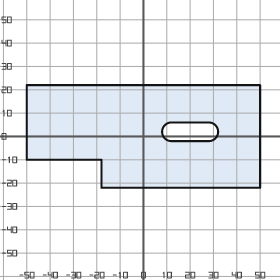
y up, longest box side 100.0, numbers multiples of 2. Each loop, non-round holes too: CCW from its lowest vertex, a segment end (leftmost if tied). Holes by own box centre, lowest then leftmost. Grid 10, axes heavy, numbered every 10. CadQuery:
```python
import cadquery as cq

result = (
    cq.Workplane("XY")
    .moveTo(-18.0, -22.0)
    .lineTo(50.0, -22.0)
    .lineTo(50.0, 22.0)
    .lineTo(-50.0, 22.0)
    .lineTo(-50.0, -10.0)
    .lineTo(-18.0, -10.0)
    .close()
    .moveTo(12.0, -2.0)
    .lineTo(28.0, -2.0)
    .threePointArc((32.0, 2.0), (28.0, 6.0))
    .lineTo(12.0, 6.0)
    .threePointArc((8.0, 2.0), (12.0, -2.0))
    .close()
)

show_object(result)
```